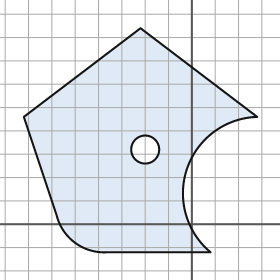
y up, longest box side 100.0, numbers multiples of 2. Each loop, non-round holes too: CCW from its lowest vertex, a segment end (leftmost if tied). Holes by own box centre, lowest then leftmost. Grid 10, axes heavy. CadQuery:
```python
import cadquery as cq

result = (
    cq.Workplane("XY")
    .moveTo(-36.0, -12.0)
    .lineTo(8.0, -12.0)
    .threePointArc((-2.0, 24.0), (28.0, 46.0))
    .lineTo(-22.0, 84.0)
    .lineTo(-72.0, 46.0)
    .lineTo(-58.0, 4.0)
    .threePointArc((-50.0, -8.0), (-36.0, -12.0))
    .close()
    .moveTo(-20.0, 32.0)
    .circle(6.0)
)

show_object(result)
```